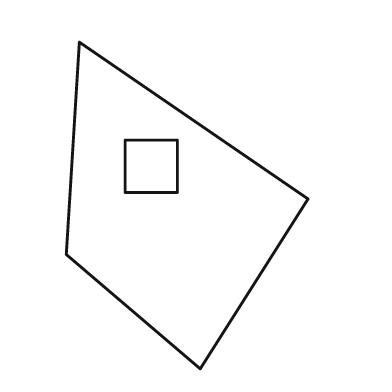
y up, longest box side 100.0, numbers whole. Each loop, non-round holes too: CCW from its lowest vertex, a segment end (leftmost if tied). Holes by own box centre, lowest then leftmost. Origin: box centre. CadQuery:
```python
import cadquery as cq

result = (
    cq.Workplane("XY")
    .moveTo(4.0, -50.0)
    .lineTo(37.0, 2.0)
    .lineTo(-33.0, 50.0)
    .lineTo(-37.0, -15.0)
    .close()
    .moveTo(-19.0, 4.0)
    .lineTo(-3.0, 4.0)
    .lineTo(-3.0, 20.0)
    .lineTo(-19.0, 20.0)
    .close()
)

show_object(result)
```